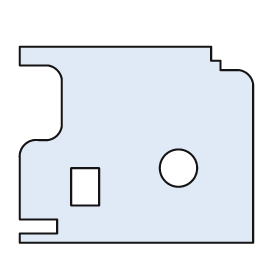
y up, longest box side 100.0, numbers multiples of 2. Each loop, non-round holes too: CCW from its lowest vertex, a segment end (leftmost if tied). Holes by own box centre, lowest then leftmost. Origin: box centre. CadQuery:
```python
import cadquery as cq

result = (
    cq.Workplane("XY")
    .moveTo(-50.0, -42.0)
    .lineTo(50.0, -42.0)
    .lineTo(50.0, 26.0)
    .threePointArc((48.0, 30.0), (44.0, 32.0))
    .lineTo(36.0, 32.0)
    .lineTo(36.0, 36.0)
    .lineTo(32.0, 36.0)
    .lineTo(32.0, 42.0)
    .lineTo(-50.0, 42.0)
    .lineTo(-50.0, 34.0)
    .lineTo(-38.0, 34.0)
    .threePointArc((-34.0, 32.0), (-32.0, 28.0))
    .lineTo(-32.0, 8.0)
    .threePointArc((-34.0, 4.0), (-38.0, 2.0))
    .lineTo(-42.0, 2.0)
    .threePointArc((-48.0, 0.0), (-50.0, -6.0))
    .lineTo(-50.0, -32.0)
    .lineTo(-34.0, -32.0)
    .lineTo(-34.0, -38.0)
    .lineTo(-50.0, -38.0)
    .close()
    .moveTo(-28.0, -26.0)
    .lineTo(-16.0, -26.0)
    .lineTo(-16.0, -10.0)
    .lineTo(-28.0, -10.0)
    .close()
    .moveTo(18.0, -10.0)
    .circle(8.0)
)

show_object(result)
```